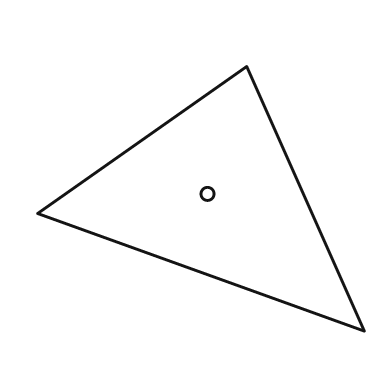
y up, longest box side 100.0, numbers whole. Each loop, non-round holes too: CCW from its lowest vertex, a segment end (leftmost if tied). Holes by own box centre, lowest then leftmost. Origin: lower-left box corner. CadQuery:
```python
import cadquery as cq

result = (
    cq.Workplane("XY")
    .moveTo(100.0, 0.0)
    .lineTo(64.0, 81.0)
    .lineTo(0.0, 36.0)
    .close()
    .moveTo(52.0, 42.0)
    .circle(2.0)
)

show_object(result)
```